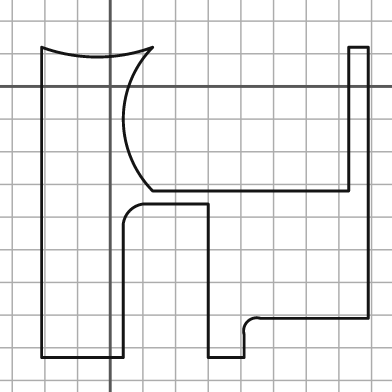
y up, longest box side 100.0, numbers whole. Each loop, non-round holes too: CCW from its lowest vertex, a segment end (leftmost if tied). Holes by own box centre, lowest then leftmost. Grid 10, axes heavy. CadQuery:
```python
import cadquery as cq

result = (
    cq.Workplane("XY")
    .moveTo(-21.0, -83.0)
    .lineTo(4.0, -83.0)
    .lineTo(4.0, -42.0)
    .threePointArc((6.0, -38.0), (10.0, -36.0))
    .lineTo(30.0, -36.0)
    .lineTo(30.0, -83.0)
    .lineTo(41.0, -83.0)
    .lineTo(41.0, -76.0)
    .threePointArc((42.0, -72.0), (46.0, -71.0))
    .lineTo(79.0, -71.0)
    .lineTo(79.0, 12.0)
    .lineTo(73.0, 12.0)
    .lineTo(73.0, -32.0)
    .lineTo(13.0, -32.0)
    .threePointArc((4.0, -10.0), (13.0, 12.0))
    .threePointArc((-4.0, 9.0), (-21.0, 12.0))
    .close()
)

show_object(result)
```